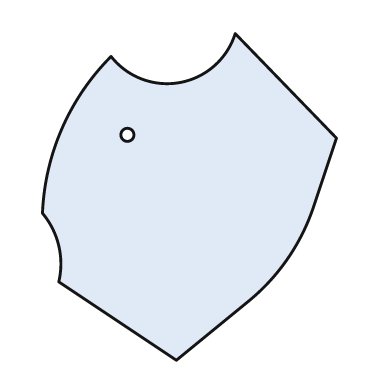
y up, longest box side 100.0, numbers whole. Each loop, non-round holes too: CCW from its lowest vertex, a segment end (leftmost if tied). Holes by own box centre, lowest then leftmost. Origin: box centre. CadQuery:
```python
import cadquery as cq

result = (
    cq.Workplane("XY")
    .moveTo(-4.0, -50.0)
    .lineTo(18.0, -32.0)
    .threePointArc((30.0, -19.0), (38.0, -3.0))
    .lineTo(45.0, 18.0)
    .lineTo(14.0, 50.0)
    .threePointArc((-3.0, 35.0), (-24.0, 43.0))
    .threePointArc((-39.0, 21.0), (-45.0, -5.0))
    .threePointArc((-40.0, -15.0), (-40.0, -26.0))
    .close()
    .moveTo(-19.0, 19.0)
    .circle(2.0)
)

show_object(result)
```